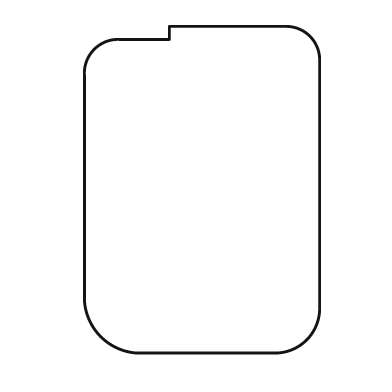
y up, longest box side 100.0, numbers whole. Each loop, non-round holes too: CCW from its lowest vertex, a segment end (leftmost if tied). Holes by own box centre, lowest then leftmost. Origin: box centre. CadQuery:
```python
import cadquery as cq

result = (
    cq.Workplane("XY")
    .moveTo(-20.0, -50.0)
    .lineTo(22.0, -50.0)
    .threePointArc((32.0, -46.0), (36.0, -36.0))
    .lineTo(36.0, 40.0)
    .threePointArc((33.0, 47.0), (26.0, 50.0))
    .lineTo(-10.0, 50.0)
    .lineTo(-10.0, 46.0)
    .lineTo(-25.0, 46.0)
    .threePointArc((-33.0, 43.0), (-36.0, 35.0))
    .lineTo(-36.0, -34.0)
    .threePointArc((-31.0, -45.0), (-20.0, -50.0))
    .close()
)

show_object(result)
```